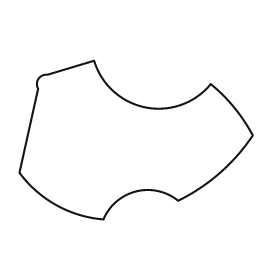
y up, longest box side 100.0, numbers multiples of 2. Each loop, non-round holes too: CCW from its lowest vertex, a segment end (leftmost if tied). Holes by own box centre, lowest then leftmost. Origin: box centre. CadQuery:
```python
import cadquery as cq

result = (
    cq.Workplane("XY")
    .moveTo(-14.0, -34.0)
    .threePointArc((0.0, -22.0), (18.0, -26.0))
    .threePointArc((36.0, -14.0), (50.0, 2.0))
    .threePointArc((42.0, 14.0), (32.0, 24.0))
    .threePointArc((4.0, 14.0), (-18.0, 34.0))
    .lineTo(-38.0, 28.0)
    .threePointArc((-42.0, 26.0), (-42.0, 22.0))
    .lineTo(-50.0, -14.0)
    .threePointArc((-34.0, -28.0), (-14.0, -34.0))
    .close()
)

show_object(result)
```